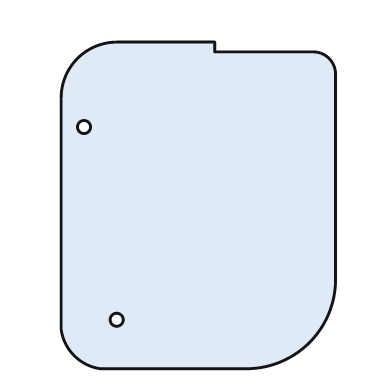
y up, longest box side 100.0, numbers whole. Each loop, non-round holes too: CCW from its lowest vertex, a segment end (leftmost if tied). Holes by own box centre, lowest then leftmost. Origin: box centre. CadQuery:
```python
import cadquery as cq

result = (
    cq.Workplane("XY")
    .moveTo(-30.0, -50.0)
    .lineTo(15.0, -50.0)
    .threePointArc((34.0, -42.0), (42.0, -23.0))
    .lineTo(42.0, 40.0)
    .threePointArc((40.0, 45.0), (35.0, 47.0))
    .lineTo(5.0, 47.0)
    .lineTo(5.0, 50.0)
    .lineTo(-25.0, 50.0)
    .threePointArc((-37.0, 45.0), (-42.0, 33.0))
    .lineTo(-42.0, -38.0)
    .threePointArc((-38.0, -46.0), (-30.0, -50.0))
    .close()
    .moveTo(-25.0, -35.0)
    .circle(2.0)
    .moveTo(-35.0, 24.0)
    .circle(2.0)
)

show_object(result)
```